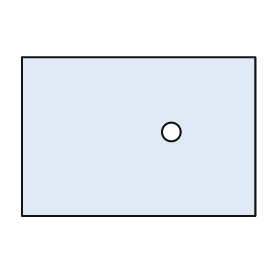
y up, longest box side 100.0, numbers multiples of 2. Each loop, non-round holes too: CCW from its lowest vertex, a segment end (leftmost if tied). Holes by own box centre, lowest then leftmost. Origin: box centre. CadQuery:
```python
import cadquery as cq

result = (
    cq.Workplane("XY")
    .moveTo(-50.0, -34.0)
    .lineTo(50.0, -34.0)
    .lineTo(50.0, 34.0)
    .lineTo(-50.0, 34.0)
    .close()
    .moveTo(14.0, 2.0)
    .circle(4.0)
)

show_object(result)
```